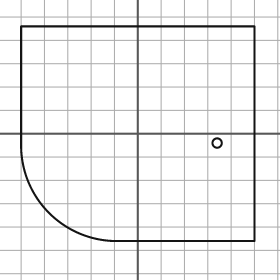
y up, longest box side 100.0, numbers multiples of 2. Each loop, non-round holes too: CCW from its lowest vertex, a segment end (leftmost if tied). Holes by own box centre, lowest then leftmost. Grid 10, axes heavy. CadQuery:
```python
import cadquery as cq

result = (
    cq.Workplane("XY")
    .moveTo(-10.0, -46.0)
    .lineTo(50.0, -46.0)
    .lineTo(50.0, 46.0)
    .lineTo(-50.0, 46.0)
    .lineTo(-50.0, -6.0)
    .threePointArc((-38.0, -34.0), (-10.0, -46.0))
    .close()
    .moveTo(34.0, -4.0)
    .circle(2.0)
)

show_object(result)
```